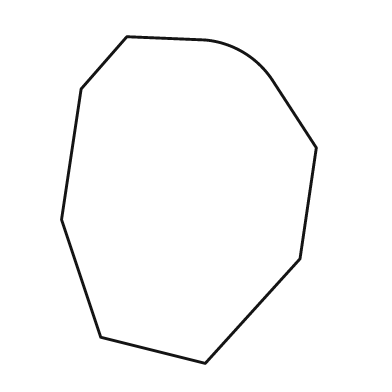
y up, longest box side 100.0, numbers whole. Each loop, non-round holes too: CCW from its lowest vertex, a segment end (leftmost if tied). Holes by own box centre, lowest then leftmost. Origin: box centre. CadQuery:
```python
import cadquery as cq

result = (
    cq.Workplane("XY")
    .moveTo(5.0, -50.0)
    .lineTo(34.0, -18.0)
    .lineTo(39.0, 16.0)
    .lineTo(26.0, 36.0)
    .threePointArc((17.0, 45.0), (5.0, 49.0))
    .lineTo(-19.0, 50.0)
    .lineTo(-33.0, 34.0)
    .lineTo(-39.0, -6.0)
    .lineTo(-27.0, -42.0)
    .close()
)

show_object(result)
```